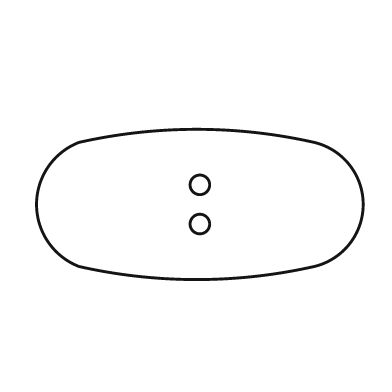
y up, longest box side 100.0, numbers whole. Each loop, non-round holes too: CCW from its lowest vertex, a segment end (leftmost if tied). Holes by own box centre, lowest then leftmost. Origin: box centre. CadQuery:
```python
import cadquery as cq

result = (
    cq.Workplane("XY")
    .moveTo(-37.0, -19.0)
    .threePointArc((-1.0, -23.0), (35.0, -19.0))
    .threePointArc((50.0, 0.0), (35.0, 19.0))
    .threePointArc((-1.0, 23.0), (-37.0, 19.0))
    .threePointArc((-50.0, 0.0), (-37.0, -19.0))
    .close()
    .moveTo(0.0, -6.0)
    .circle(3.0)
    .moveTo(0.0, 6.0)
    .circle(3.0)
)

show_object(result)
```